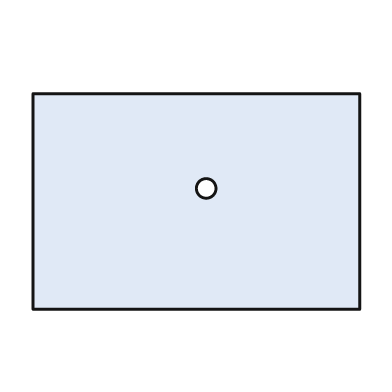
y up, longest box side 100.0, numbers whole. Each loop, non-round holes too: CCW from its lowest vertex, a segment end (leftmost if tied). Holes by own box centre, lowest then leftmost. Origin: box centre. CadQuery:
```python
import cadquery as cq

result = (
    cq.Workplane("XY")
    .moveTo(-50.0, -33.0)
    .lineTo(50.0, -33.0)
    .lineTo(50.0, 33.0)
    .lineTo(-50.0, 33.0)
    .close()
    .moveTo(3.0, 4.0)
    .circle(3.0)
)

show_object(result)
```